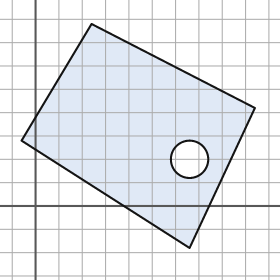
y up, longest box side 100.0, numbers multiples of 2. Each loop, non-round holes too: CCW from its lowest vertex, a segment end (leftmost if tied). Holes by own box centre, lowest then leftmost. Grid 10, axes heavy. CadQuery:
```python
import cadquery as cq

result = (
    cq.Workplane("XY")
    .moveTo(66.0, -18.0)
    .lineTo(94.0, 42.0)
    .lineTo(24.0, 78.0)
    .lineTo(-6.0, 28.0)
    .close()
    .moveTo(66.0, 20.0)
    .circle(8.0)
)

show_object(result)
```